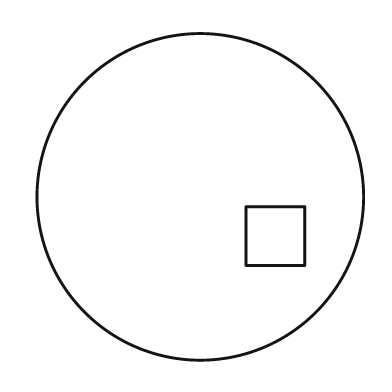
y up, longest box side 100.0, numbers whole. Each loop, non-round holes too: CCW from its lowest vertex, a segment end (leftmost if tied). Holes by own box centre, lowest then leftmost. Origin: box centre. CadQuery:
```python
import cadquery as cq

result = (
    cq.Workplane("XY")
    .moveTo(0.0, 0.0)
    .circle(50.0)
    .moveTo(14.0, -21.0)
    .lineTo(32.0, -21.0)
    .lineTo(32.0, -3.0)
    .lineTo(14.0, -3.0)
    .close()
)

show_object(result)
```